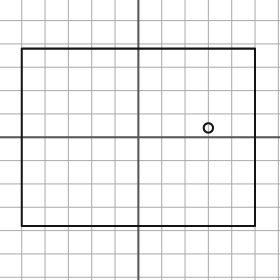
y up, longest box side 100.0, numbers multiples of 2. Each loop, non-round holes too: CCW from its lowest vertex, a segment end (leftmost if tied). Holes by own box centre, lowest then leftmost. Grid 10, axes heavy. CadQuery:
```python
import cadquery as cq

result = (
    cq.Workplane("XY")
    .moveTo(-50.0, -38.0)
    .lineTo(50.0, -38.0)
    .lineTo(50.0, 38.0)
    .lineTo(-50.0, 38.0)
    .close()
    .moveTo(30.0, 4.0)
    .circle(2.0)
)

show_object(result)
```